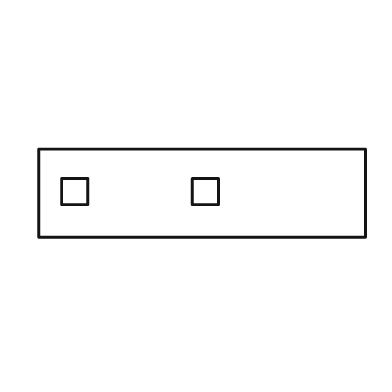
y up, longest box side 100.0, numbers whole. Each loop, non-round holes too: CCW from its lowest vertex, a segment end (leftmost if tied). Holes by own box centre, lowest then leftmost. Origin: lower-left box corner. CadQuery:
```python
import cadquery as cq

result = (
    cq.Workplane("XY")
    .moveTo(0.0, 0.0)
    .lineTo(100.0, 0.0)
    .lineTo(100.0, 27.0)
    .lineTo(0.0, 27.0)
    .close()
    .moveTo(7.0, 10.0)
    .lineTo(15.0, 10.0)
    .lineTo(15.0, 18.0)
    .lineTo(7.0, 18.0)
    .close()
    .moveTo(47.0, 10.0)
    .lineTo(55.0, 10.0)
    .lineTo(55.0, 18.0)
    .lineTo(47.0, 18.0)
    .close()
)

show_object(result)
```